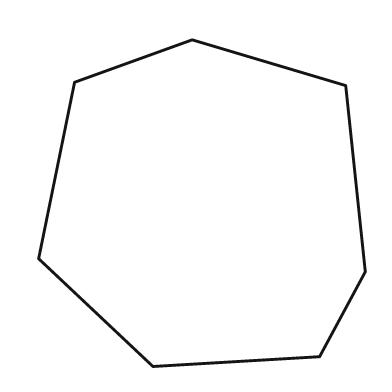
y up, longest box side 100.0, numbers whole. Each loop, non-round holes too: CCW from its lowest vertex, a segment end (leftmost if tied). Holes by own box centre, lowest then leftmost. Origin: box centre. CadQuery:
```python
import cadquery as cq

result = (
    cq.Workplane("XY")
    .moveTo(-15.0, -50.0)
    .lineTo(36.0, -47.0)
    .lineTo(50.0, -21.0)
    .lineTo(44.0, 36.0)
    .lineTo(-3.0, 50.0)
    .lineTo(-39.0, 37.0)
    .lineTo(-50.0, -17.0)
    .close()
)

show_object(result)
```